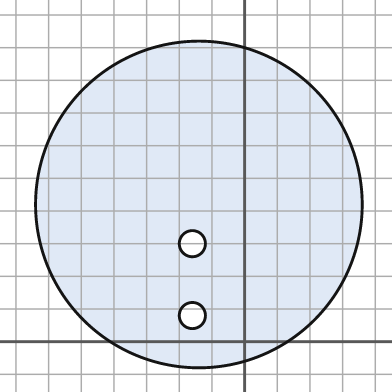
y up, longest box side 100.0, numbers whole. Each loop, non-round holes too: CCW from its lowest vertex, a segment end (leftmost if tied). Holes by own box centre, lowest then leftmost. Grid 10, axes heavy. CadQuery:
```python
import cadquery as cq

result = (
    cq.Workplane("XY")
    .moveTo(-14.0, 42.0)
    .circle(50.0)
    .moveTo(-16.0, 8.0)
    .circle(4.0)
    .moveTo(-16.0, 30.0)
    .circle(4.0)
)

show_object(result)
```